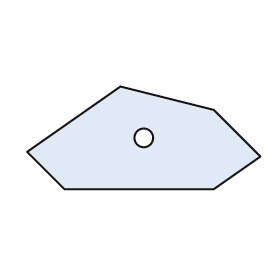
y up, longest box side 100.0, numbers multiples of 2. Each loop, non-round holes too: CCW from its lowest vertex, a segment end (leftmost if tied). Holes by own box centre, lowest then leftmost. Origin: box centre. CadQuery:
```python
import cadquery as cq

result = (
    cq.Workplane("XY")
    .moveTo(-34.0, -22.0)
    .lineTo(30.0, -22.0)
    .lineTo(50.0, -8.0)
    .lineTo(30.0, 12.0)
    .lineTo(-10.0, 22.0)
    .lineTo(-50.0, -6.0)
    .close()
    .moveTo(0.0, 0.0)
    .circle(4.0)
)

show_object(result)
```